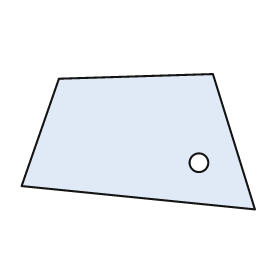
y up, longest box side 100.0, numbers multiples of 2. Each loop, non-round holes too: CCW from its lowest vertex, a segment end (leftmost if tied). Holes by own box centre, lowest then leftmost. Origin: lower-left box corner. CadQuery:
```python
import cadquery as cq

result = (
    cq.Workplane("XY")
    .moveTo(100.0, 0.0)
    .lineTo(82.0, 58.0)
    .lineTo(16.0, 56.0)
    .lineTo(0.0, 10.0)
    .close()
    .moveTo(76.0, 20.0)
    .circle(4.0)
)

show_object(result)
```